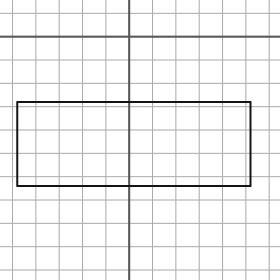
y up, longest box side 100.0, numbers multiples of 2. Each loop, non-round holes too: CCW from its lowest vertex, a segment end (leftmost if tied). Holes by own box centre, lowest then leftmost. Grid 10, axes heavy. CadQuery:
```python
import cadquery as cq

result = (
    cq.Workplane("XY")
    .moveTo(-48.0, -64.0)
    .lineTo(52.0, -64.0)
    .lineTo(52.0, -28.0)
    .lineTo(-48.0, -28.0)
    .close()
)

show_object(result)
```